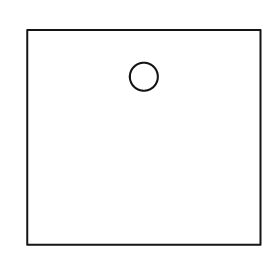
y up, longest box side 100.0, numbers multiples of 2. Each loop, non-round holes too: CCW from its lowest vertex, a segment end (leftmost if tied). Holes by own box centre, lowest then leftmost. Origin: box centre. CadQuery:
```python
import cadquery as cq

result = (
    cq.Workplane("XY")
    .moveTo(-50.0, -46.0)
    .lineTo(50.0, -46.0)
    .lineTo(50.0, 46.0)
    .lineTo(-50.0, 46.0)
    .close()
    .moveTo(0.0, 26.0)
    .circle(6.0)
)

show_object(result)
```